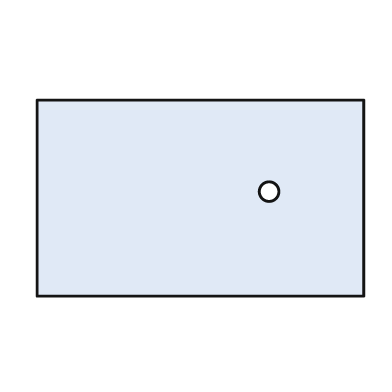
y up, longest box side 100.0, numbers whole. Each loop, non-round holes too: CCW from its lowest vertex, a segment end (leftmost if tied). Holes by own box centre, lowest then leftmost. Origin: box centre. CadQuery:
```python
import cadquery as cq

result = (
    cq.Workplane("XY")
    .moveTo(-50.0, -30.0)
    .lineTo(50.0, -30.0)
    .lineTo(50.0, 30.0)
    .lineTo(-50.0, 30.0)
    .close()
    .moveTo(21.0, 2.0)
    .circle(3.0)
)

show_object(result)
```